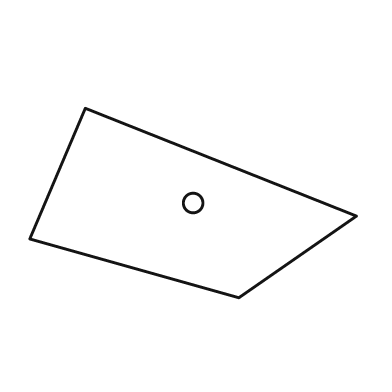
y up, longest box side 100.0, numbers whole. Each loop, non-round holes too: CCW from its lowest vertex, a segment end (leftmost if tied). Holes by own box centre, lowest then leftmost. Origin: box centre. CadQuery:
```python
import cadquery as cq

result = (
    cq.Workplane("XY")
    .moveTo(14.0, -29.0)
    .lineTo(50.0, -4.0)
    .lineTo(-33.0, 29.0)
    .lineTo(-50.0, -11.0)
    .close()
    .moveTo(0.0, 0.0)
    .circle(3.0)
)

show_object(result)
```